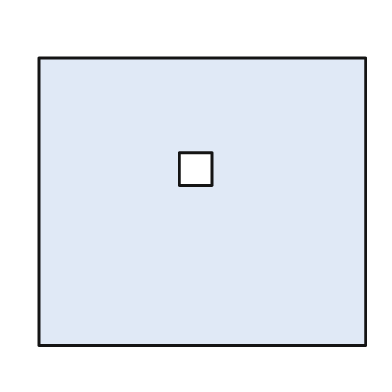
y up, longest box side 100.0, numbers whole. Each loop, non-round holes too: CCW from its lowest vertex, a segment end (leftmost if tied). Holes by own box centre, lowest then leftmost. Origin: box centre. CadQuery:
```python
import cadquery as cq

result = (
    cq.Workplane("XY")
    .moveTo(-50.0, -44.0)
    .lineTo(50.0, -44.0)
    .lineTo(50.0, 44.0)
    .lineTo(-50.0, 44.0)
    .close()
    .moveTo(-7.0, 5.0)
    .lineTo(3.0, 5.0)
    .lineTo(3.0, 15.0)
    .lineTo(-7.0, 15.0)
    .close()
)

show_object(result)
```